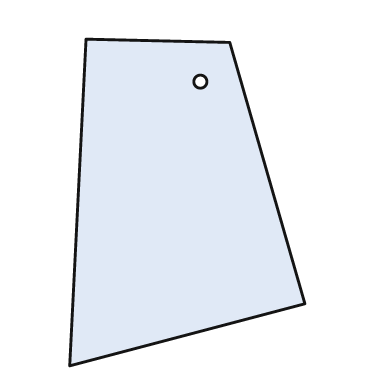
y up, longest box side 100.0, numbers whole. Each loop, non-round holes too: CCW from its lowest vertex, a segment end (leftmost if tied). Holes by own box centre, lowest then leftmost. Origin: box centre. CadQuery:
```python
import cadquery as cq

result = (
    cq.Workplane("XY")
    .moveTo(-36.0, -50.0)
    .lineTo(36.0, -31.0)
    .lineTo(13.0, 49.0)
    .lineTo(-31.0, 50.0)
    .close()
    .moveTo(4.0, 37.0)
    .circle(2.0)
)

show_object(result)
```